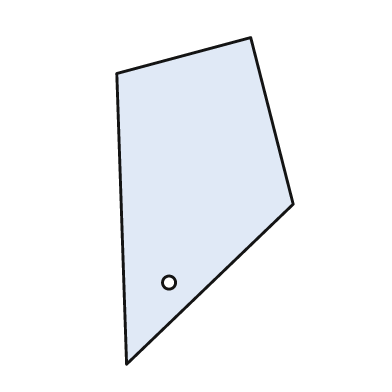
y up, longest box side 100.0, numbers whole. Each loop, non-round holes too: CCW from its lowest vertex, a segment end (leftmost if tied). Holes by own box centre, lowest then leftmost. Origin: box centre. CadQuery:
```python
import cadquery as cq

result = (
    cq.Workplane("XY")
    .moveTo(-24.0, -50.0)
    .lineTo(27.0, -1.0)
    .lineTo(14.0, 50.0)
    .lineTo(-27.0, 39.0)
    .close()
    .moveTo(-11.0, -25.0)
    .circle(2.0)
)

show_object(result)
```